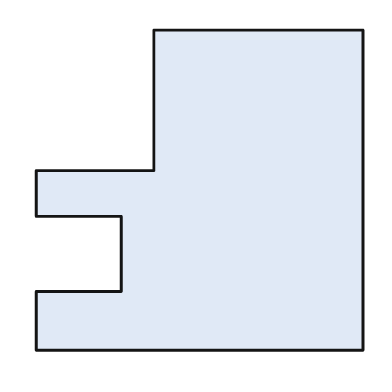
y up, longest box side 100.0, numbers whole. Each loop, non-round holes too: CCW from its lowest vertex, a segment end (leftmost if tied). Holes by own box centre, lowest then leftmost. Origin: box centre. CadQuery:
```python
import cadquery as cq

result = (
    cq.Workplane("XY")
    .moveTo(-50.0, -49.0)
    .lineTo(50.0, -49.0)
    .lineTo(50.0, 49.0)
    .lineTo(-14.0, 49.0)
    .lineTo(-14.0, 6.0)
    .lineTo(-50.0, 6.0)
    .lineTo(-50.0, -8.0)
    .lineTo(-24.0, -8.0)
    .lineTo(-24.0, -31.0)
    .lineTo(-50.0, -31.0)
    .close()
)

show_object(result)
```